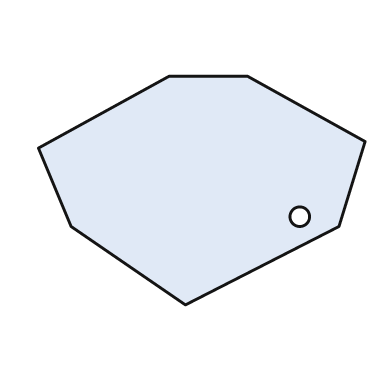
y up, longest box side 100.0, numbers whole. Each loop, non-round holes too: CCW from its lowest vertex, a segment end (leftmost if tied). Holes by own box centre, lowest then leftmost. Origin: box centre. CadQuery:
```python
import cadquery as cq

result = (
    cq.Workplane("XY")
    .moveTo(-5.0, -35.0)
    .lineTo(42.0, -11.0)
    .lineTo(50.0, 15.0)
    .lineTo(14.0, 35.0)
    .lineTo(-10.0, 35.0)
    .lineTo(-50.0, 13.0)
    .lineTo(-40.0, -11.0)
    .close()
    .moveTo(30.0, -8.0)
    .circle(3.0)
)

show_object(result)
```